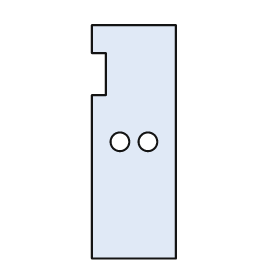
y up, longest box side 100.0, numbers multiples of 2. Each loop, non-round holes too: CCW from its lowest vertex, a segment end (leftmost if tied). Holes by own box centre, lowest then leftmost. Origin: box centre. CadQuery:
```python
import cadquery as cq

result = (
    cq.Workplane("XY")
    .moveTo(-18.0, -50.0)
    .lineTo(18.0, -50.0)
    .lineTo(18.0, 50.0)
    .lineTo(-18.0, 50.0)
    .lineTo(-18.0, 38.0)
    .lineTo(-12.0, 38.0)
    .lineTo(-12.0, 20.0)
    .lineTo(-18.0, 20.0)
    .close()
    .moveTo(-6.0, 0.0)
    .circle(4.0)
    .moveTo(6.0, 0.0)
    .circle(4.0)
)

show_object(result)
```